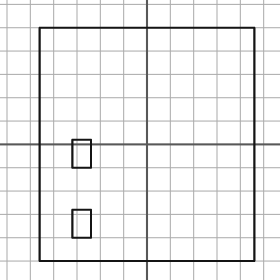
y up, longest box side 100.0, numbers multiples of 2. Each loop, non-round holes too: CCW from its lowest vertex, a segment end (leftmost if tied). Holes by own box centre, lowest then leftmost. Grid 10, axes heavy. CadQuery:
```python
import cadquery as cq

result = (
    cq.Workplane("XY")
    .moveTo(-46.0, -50.0)
    .lineTo(46.0, -50.0)
    .lineTo(46.0, 50.0)
    .lineTo(-46.0, 50.0)
    .close()
    .moveTo(-32.0, -40.0)
    .lineTo(-24.0, -40.0)
    .lineTo(-24.0, -28.0)
    .lineTo(-32.0, -28.0)
    .close()
    .moveTo(-32.0, -10.0)
    .lineTo(-24.0, -10.0)
    .lineTo(-24.0, 2.0)
    .lineTo(-32.0, 2.0)
    .close()
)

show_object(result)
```